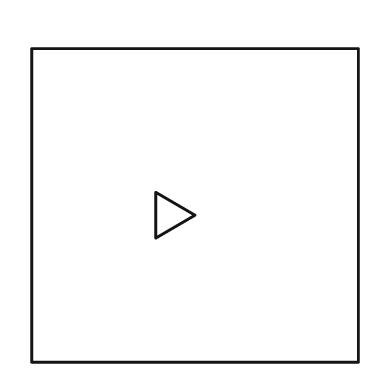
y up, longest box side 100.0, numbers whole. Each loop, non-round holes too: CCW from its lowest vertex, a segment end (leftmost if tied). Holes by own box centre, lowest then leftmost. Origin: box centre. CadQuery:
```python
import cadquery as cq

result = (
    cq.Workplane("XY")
    .moveTo(-50.0, -48.0)
    .lineTo(50.0, -48.0)
    .lineTo(50.0, 48.0)
    .lineTo(-50.0, 48.0)
    .close()
    .moveTo(-12.0, -10.0)
    .lineTo(0.0, -3.0)
    .lineTo(-12.0, 4.0)
    .close()
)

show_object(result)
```